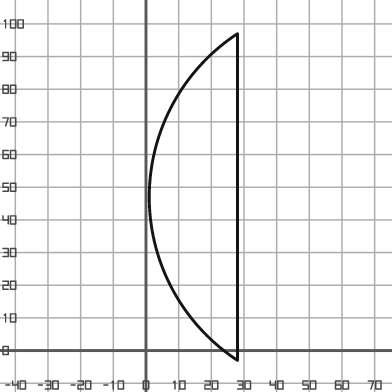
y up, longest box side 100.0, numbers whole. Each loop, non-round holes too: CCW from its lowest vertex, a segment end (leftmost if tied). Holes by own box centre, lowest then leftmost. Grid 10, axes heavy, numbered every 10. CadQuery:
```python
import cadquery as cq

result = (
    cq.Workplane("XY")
    .moveTo(28.0, -3.0)
    .lineTo(28.0, 97.0)
    .threePointArc((1.0, 47.0), (28.0, -3.0))
    .close()
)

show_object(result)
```